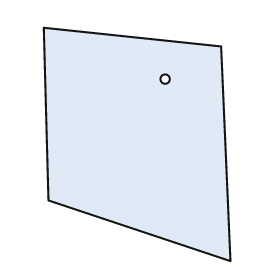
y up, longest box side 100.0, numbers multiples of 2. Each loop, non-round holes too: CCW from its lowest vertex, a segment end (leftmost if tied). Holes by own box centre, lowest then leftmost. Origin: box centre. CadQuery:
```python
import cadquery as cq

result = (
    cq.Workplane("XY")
    .moveTo(40.0, -50.0)
    .lineTo(36.0, 42.0)
    .lineTo(-40.0, 50.0)
    .lineTo(-38.0, -24.0)
    .close()
    .moveTo(12.0, 28.0)
    .circle(2.0)
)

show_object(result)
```